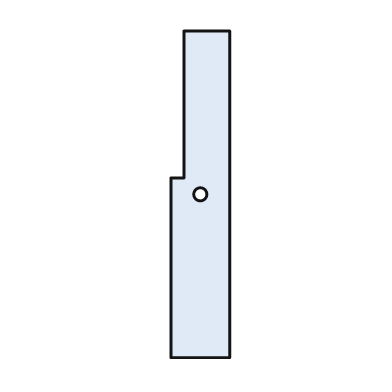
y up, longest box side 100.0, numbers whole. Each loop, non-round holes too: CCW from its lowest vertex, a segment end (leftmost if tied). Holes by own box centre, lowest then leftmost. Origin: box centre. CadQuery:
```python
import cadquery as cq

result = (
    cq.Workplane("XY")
    .moveTo(-9.0, -50.0)
    .lineTo(9.0, -50.0)
    .lineTo(9.0, 50.0)
    .lineTo(-5.0, 50.0)
    .lineTo(-5.0, 5.0)
    .lineTo(-9.0, 5.0)
    .close()
    .moveTo(0.0, 0.0)
    .circle(2.0)
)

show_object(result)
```